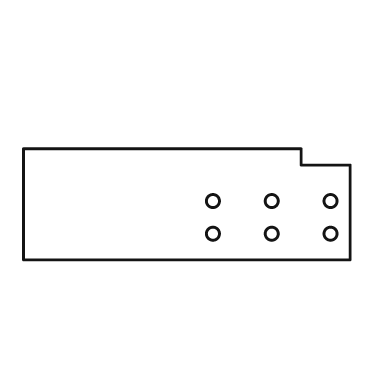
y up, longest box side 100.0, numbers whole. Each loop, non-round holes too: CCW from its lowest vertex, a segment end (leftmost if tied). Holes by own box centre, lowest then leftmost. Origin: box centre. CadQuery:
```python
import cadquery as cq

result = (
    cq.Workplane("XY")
    .moveTo(-50.0, -17.0)
    .lineTo(50.0, -17.0)
    .lineTo(50.0, 12.0)
    .lineTo(35.0, 12.0)
    .lineTo(35.0, 17.0)
    .lineTo(-50.0, 17.0)
    .close()
    .moveTo(8.0, -9.0)
    .circle(2.0)
    .moveTo(26.0, -9.0)
    .circle(2.0)
    .moveTo(44.0, -9.0)
    .circle(2.0)
    .moveTo(8.0, 1.0)
    .circle(2.0)
    .moveTo(26.0, 1.0)
    .circle(2.0)
    .moveTo(44.0, 1.0)
    .circle(2.0)
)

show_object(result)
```